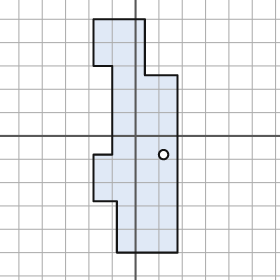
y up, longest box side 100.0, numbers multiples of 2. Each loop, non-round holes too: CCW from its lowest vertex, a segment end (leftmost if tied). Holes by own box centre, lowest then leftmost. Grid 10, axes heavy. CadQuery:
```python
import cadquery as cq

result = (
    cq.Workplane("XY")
    .moveTo(-8.0, -50.0)
    .lineTo(18.0, -50.0)
    .lineTo(18.0, 26.0)
    .lineTo(4.0, 26.0)
    .lineTo(4.0, 50.0)
    .lineTo(-18.0, 50.0)
    .lineTo(-18.0, 30.0)
    .lineTo(-10.0, 30.0)
    .lineTo(-10.0, -8.0)
    .lineTo(-18.0, -8.0)
    .lineTo(-18.0, -28.0)
    .lineTo(-8.0, -28.0)
    .close()
    .moveTo(12.0, -8.0)
    .circle(2.0)
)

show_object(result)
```